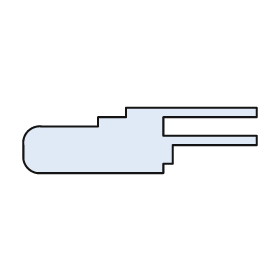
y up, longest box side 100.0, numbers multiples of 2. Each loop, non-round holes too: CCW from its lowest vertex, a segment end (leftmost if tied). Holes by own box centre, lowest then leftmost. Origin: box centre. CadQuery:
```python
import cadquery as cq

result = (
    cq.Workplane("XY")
    .moveTo(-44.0, -14.0)
    .lineTo(10.0, -14.0)
    .lineTo(10.0, -10.0)
    .lineTo(14.0, -10.0)
    .lineTo(14.0, -2.0)
    .lineTo(50.0, -2.0)
    .lineTo(50.0, 2.0)
    .lineTo(10.0, 2.0)
    .lineTo(10.0, 10.0)
    .lineTo(50.0, 10.0)
    .lineTo(50.0, 14.0)
    .lineTo(-6.0, 14.0)
    .lineTo(-6.0, 10.0)
    .lineTo(-18.0, 10.0)
    .lineTo(-18.0, 6.0)
    .lineTo(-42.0, 6.0)
    .threePointArc((-48.0, 4.0), (-50.0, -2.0))
    .lineTo(-50.0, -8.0)
    .threePointArc((-48.0, -12.0), (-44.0, -14.0))
    .close()
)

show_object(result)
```